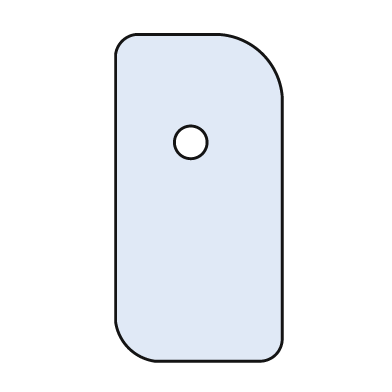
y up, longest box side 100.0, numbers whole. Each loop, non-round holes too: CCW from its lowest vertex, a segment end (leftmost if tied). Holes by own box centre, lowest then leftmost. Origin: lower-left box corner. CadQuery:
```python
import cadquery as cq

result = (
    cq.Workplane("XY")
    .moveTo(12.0, 0.0)
    .lineTo(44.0, 0.0)
    .threePointArc((49.0, 2.0), (51.0, 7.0))
    .lineTo(51.0, 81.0)
    .threePointArc((45.0, 94.0), (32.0, 100.0))
    .lineTo(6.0, 100.0)
    .threePointArc((2.0, 98.0), (0.0, 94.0))
    .lineTo(0.0, 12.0)
    .threePointArc((4.0, 4.0), (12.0, 0.0))
    .close()
    .moveTo(23.0, 67.0)
    .circle(5.0)
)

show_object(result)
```